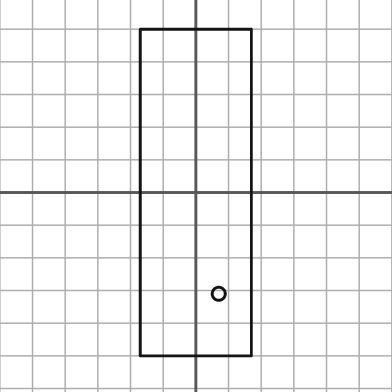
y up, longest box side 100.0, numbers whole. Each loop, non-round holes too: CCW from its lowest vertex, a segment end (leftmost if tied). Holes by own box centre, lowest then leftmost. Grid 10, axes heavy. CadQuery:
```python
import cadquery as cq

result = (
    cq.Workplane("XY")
    .moveTo(-17.0, -50.0)
    .lineTo(17.0, -50.0)
    .lineTo(17.0, 50.0)
    .lineTo(-17.0, 50.0)
    .close()
    .moveTo(7.0, -31.0)
    .circle(2.0)
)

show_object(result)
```